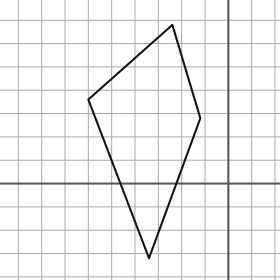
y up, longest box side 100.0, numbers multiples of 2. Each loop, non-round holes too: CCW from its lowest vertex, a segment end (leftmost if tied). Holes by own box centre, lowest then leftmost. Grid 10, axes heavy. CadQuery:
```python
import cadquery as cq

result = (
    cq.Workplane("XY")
    .moveTo(-34.0, -32.0)
    .lineTo(-12.0, 28.0)
    .lineTo(-24.0, 68.0)
    .lineTo(-60.0, 36.0)
    .close()
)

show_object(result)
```